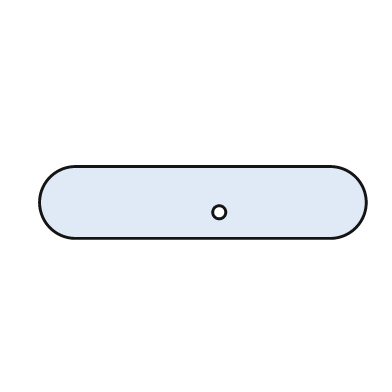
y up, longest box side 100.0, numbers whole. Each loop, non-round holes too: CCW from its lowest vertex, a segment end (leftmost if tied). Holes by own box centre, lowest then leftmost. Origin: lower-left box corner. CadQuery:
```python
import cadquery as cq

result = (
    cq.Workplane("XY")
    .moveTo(11.0, 0.0)
    .lineTo(89.0, 0.0)
    .threePointArc((100.0, 11.0), (89.0, 22.0))
    .lineTo(11.0, 22.0)
    .threePointArc((0.0, 11.0), (11.0, 0.0))
    .close()
    .moveTo(55.0, 8.0)
    .circle(2.0)
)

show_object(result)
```